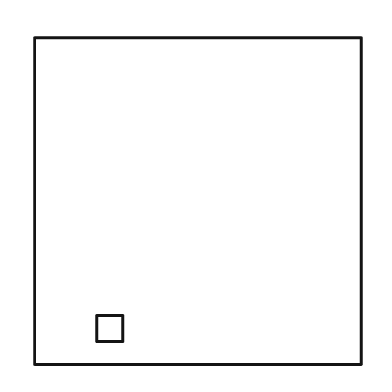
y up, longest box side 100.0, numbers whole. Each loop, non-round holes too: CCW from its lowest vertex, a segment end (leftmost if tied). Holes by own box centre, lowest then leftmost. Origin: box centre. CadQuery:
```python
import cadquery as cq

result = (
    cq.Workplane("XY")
    .moveTo(-50.0, -50.0)
    .lineTo(50.0, -50.0)
    .lineTo(50.0, 50.0)
    .lineTo(-50.0, 50.0)
    .close()
    .moveTo(-31.0, -43.0)
    .lineTo(-23.0, -43.0)
    .lineTo(-23.0, -35.0)
    .lineTo(-31.0, -35.0)
    .close()
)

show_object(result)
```